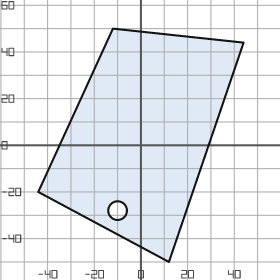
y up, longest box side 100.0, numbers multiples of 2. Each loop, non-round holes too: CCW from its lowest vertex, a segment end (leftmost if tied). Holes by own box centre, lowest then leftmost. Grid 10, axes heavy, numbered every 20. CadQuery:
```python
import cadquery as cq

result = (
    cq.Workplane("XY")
    .moveTo(12.0, -50.0)
    .lineTo(44.0, 44.0)
    .lineTo(-12.0, 50.0)
    .lineTo(-44.0, -20.0)
    .close()
    .moveTo(-10.0, -28.0)
    .circle(4.0)
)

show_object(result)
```